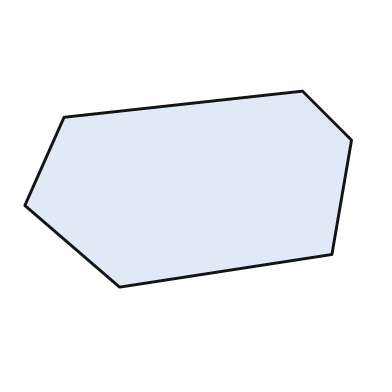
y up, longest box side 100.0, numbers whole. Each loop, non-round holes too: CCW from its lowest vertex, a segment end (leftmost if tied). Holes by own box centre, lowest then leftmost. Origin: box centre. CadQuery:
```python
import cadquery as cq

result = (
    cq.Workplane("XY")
    .moveTo(-21.0, -30.0)
    .lineTo(44.0, -20.0)
    .lineTo(50.0, 15.0)
    .lineTo(35.0, 30.0)
    .lineTo(-38.0, 22.0)
    .lineTo(-50.0, -5.0)
    .close()
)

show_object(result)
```